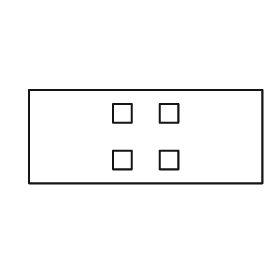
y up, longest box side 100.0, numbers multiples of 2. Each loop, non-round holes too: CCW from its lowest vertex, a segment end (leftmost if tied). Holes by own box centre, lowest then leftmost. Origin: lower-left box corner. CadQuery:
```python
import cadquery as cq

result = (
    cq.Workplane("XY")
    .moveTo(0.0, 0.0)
    .lineTo(100.0, 0.0)
    .lineTo(100.0, 40.0)
    .lineTo(0.0, 40.0)
    .close()
    .moveTo(36.0, 6.0)
    .lineTo(44.0, 6.0)
    .lineTo(44.0, 14.0)
    .lineTo(36.0, 14.0)
    .close()
    .moveTo(56.0, 6.0)
    .lineTo(64.0, 6.0)
    .lineTo(64.0, 14.0)
    .lineTo(56.0, 14.0)
    .close()
    .moveTo(36.0, 26.0)
    .lineTo(44.0, 26.0)
    .lineTo(44.0, 34.0)
    .lineTo(36.0, 34.0)
    .close()
    .moveTo(56.0, 26.0)
    .lineTo(64.0, 26.0)
    .lineTo(64.0, 34.0)
    .lineTo(56.0, 34.0)
    .close()
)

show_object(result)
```